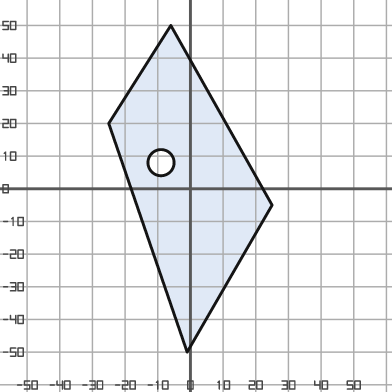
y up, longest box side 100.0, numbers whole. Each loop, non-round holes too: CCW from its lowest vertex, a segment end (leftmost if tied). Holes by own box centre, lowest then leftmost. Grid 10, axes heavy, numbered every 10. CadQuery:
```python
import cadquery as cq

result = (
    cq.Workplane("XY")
    .moveTo(-1.0, -50.0)
    .lineTo(25.0, -5.0)
    .lineTo(-6.0, 50.0)
    .lineTo(-25.0, 20.0)
    .close()
    .moveTo(-9.0, 8.0)
    .circle(4.0)
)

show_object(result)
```